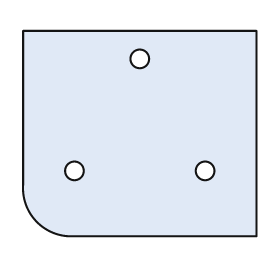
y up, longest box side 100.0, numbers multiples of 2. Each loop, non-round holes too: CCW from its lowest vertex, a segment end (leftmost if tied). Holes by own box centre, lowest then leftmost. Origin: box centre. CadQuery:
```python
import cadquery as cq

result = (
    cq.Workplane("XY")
    .moveTo(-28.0, -44.0)
    .lineTo(50.0, -44.0)
    .lineTo(50.0, 44.0)
    .lineTo(-50.0, 44.0)
    .lineTo(-50.0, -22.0)
    .threePointArc((-44.0, -38.0), (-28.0, -44.0))
    .close()
    .moveTo(-28.0, -16.0)
    .circle(4.0)
    .moveTo(28.0, -16.0)
    .circle(4.0)
    .moveTo(0.0, 32.0)
    .circle(4.0)
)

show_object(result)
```